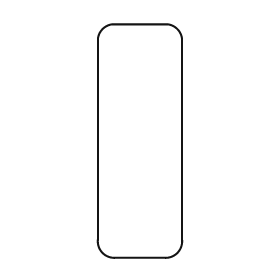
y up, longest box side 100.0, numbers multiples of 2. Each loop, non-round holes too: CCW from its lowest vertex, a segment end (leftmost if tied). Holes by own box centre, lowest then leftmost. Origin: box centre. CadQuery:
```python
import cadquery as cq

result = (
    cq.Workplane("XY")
    .moveTo(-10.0, -50.0)
    .lineTo(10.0, -50.0)
    .threePointArc((16.0, -48.0), (18.0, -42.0))
    .lineTo(18.0, 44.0)
    .threePointArc((16.0, 48.0), (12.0, 50.0))
    .lineTo(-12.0, 50.0)
    .threePointArc((-16.0, 48.0), (-18.0, 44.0))
    .lineTo(-18.0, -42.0)
    .threePointArc((-16.0, -48.0), (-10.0, -50.0))
    .close()
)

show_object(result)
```